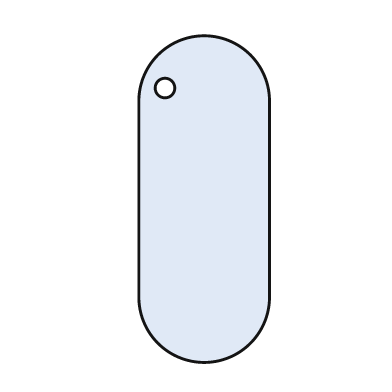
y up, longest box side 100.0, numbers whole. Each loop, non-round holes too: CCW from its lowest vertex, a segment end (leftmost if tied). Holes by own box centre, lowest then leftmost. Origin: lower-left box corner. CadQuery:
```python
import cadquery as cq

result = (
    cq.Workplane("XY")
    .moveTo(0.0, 20.0)
    .threePointArc((20.0, 0.0), (40.0, 20.0))
    .lineTo(40.0, 80.0)
    .threePointArc((20.0, 100.0), (0.0, 80.0))
    .close()
    .moveTo(8.0, 84.0)
    .circle(3.0)
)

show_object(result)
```